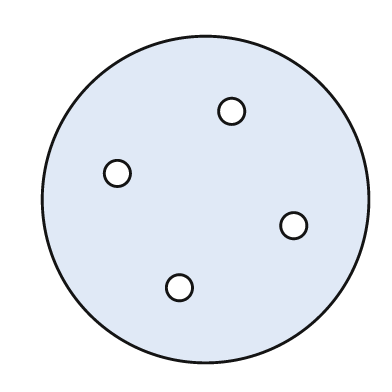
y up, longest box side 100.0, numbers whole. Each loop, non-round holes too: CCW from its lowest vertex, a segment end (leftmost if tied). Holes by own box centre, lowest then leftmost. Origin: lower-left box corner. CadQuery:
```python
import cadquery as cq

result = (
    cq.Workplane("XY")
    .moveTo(50.0, 50.0)
    .circle(50.0)
    .moveTo(42.0, 23.0)
    .circle(4.0)
    .moveTo(77.0, 42.0)
    .circle(4.0)
    .moveTo(23.0, 58.0)
    .circle(4.0)
    .moveTo(58.0, 77.0)
    .circle(4.0)
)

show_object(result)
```